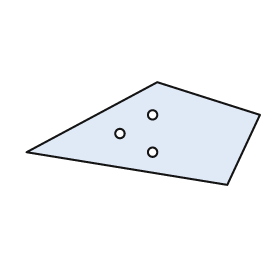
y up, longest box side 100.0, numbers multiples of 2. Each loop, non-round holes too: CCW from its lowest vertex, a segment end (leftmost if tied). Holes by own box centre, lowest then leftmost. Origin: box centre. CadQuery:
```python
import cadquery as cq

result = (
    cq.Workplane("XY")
    .moveTo(36.0, -22.0)
    .lineTo(50.0, 8.0)
    .lineTo(6.0, 22.0)
    .lineTo(-50.0, -8.0)
    .close()
    .moveTo(4.0, -8.0)
    .circle(2.0)
    .moveTo(-10.0, 0.0)
    .circle(2.0)
    .moveTo(4.0, 8.0)
    .circle(2.0)
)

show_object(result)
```